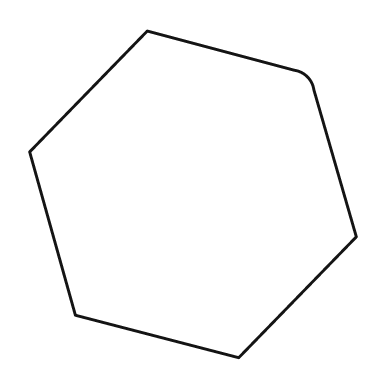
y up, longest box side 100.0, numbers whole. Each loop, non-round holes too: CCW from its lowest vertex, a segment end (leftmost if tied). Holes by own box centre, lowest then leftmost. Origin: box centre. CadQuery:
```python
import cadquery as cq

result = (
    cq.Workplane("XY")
    .moveTo(14.0, -50.0)
    .lineTo(50.0, -13.0)
    .lineTo(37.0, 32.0)
    .threePointArc((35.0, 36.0), (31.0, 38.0))
    .lineTo(-14.0, 50.0)
    .lineTo(-50.0, 13.0)
    .lineTo(-36.0, -37.0)
    .close()
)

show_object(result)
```